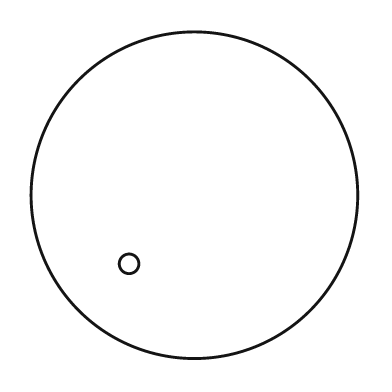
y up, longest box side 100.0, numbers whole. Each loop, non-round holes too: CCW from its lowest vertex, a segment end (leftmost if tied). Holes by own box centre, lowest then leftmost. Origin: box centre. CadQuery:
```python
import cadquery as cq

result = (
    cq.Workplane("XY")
    .moveTo(0.0, 0.0)
    .circle(50.0)
    .moveTo(-20.0, -21.0)
    .circle(3.0)
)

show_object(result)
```